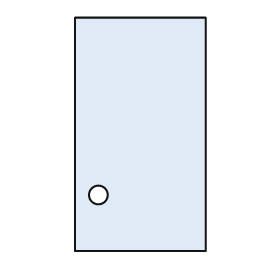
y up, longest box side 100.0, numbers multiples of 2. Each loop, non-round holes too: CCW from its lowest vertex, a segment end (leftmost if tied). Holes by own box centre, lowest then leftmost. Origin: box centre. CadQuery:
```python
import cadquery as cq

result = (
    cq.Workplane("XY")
    .moveTo(-28.0, -50.0)
    .lineTo(28.0, -50.0)
    .lineTo(28.0, 50.0)
    .lineTo(-28.0, 50.0)
    .close()
    .moveTo(-18.0, -26.0)
    .circle(4.0)
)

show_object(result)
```